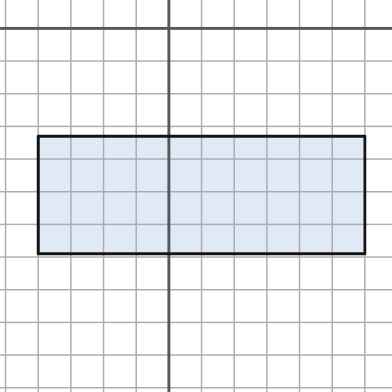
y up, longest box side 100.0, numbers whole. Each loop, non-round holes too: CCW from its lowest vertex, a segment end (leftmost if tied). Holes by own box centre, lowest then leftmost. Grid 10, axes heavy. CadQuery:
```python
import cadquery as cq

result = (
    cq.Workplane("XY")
    .moveTo(-40.0, -69.0)
    .lineTo(60.0, -69.0)
    .lineTo(60.0, -33.0)
    .lineTo(-40.0, -33.0)
    .close()
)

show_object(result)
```